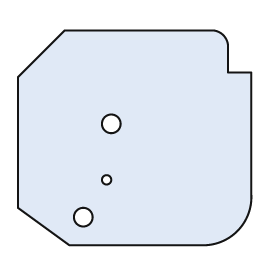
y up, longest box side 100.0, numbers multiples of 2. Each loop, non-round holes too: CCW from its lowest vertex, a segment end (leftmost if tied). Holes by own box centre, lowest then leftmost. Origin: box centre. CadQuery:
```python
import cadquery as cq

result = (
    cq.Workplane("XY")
    .moveTo(-28.0, -46.0)
    .lineTo(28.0, -46.0)
    .threePointArc((44.0, -40.0), (50.0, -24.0))
    .lineTo(50.0, 28.0)
    .lineTo(40.0, 28.0)
    .lineTo(40.0, 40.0)
    .threePointArc((38.0, 44.0), (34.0, 46.0))
    .lineTo(-30.0, 46.0)
    .lineTo(-50.0, 26.0)
    .lineTo(-50.0, -30.0)
    .close()
    .moveTo(-22.0, -34.0)
    .circle(4.0)
    .moveTo(-12.0, -18.0)
    .circle(2.0)
    .moveTo(-10.0, 6.0)
    .circle(4.0)
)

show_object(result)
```